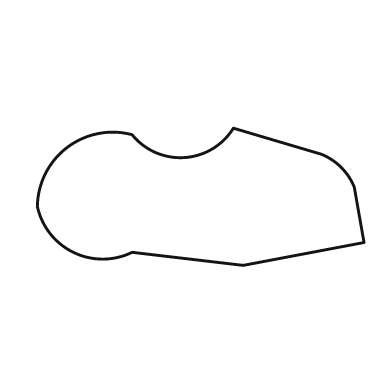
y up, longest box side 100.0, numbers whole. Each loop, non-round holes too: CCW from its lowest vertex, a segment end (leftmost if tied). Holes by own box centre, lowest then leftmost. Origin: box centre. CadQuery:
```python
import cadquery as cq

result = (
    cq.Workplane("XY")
    .moveTo(13.0, -21.0)
    .lineTo(50.0, -14.0)
    .lineTo(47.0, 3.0)
    .threePointArc((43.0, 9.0), (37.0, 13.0))
    .lineTo(10.0, 21.0)
    .threePointArc((-5.0, 12.0), (-21.0, 19.0))
    .threePointArc((-41.0, 15.0), (-50.0, -3.0))
    .threePointArc((-39.0, -17.0), (-21.0, -17.0))
    .close()
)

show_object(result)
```